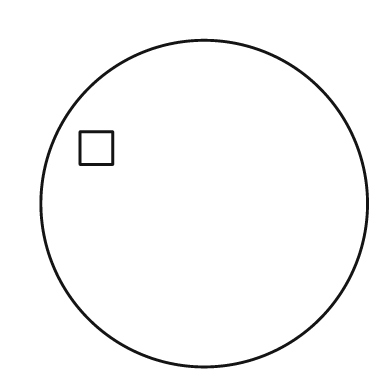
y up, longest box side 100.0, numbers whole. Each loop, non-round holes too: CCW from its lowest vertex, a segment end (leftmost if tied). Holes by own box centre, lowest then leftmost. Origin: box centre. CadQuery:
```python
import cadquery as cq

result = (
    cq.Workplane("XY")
    .moveTo(0.0, 0.0)
    .circle(50.0)
    .moveTo(-38.0, 12.0)
    .lineTo(-28.0, 12.0)
    .lineTo(-28.0, 22.0)
    .lineTo(-38.0, 22.0)
    .close()
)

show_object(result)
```